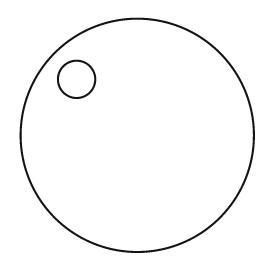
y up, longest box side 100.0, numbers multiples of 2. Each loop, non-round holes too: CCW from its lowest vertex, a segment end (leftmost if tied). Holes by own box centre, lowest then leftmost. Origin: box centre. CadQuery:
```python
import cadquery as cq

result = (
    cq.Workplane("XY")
    .moveTo(0.0, 0.0)
    .circle(50.0)
    .moveTo(-26.0, 24.0)
    .circle(8.0)
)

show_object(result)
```